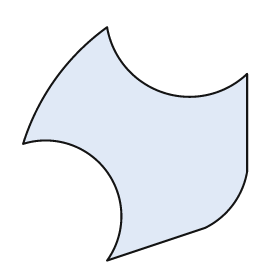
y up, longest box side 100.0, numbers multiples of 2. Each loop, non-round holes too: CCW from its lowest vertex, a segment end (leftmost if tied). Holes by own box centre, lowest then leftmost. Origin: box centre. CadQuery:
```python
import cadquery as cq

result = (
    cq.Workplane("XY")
    .moveTo(-12.0, -50.0)
    .lineTo(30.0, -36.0)
    .threePointArc((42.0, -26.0), (48.0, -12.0))
    .lineTo(48.0, 30.0)
    .threePointArc((12.0, 22.0), (-12.0, 50.0))
    .threePointArc((-34.0, 28.0), (-48.0, 0.0))
    .threePointArc((-12.0, -12.0), (-12.0, -50.0))
    .close()
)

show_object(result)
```